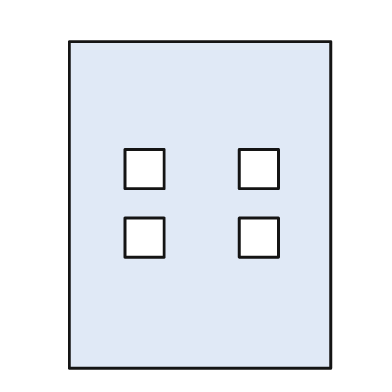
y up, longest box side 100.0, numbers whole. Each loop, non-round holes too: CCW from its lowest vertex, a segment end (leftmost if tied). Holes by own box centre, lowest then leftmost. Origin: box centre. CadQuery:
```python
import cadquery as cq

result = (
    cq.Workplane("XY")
    .moveTo(-40.0, -50.0)
    .lineTo(40.0, -50.0)
    .lineTo(40.0, 50.0)
    .lineTo(-40.0, 50.0)
    .close()
    .moveTo(-23.0, -16.0)
    .lineTo(-11.0, -16.0)
    .lineTo(-11.0, -4.0)
    .lineTo(-23.0, -4.0)
    .close()
    .moveTo(12.0, -16.0)
    .lineTo(24.0, -16.0)
    .lineTo(24.0, -4.0)
    .lineTo(12.0, -4.0)
    .close()
    .moveTo(-23.0, 5.0)
    .lineTo(-11.0, 5.0)
    .lineTo(-11.0, 17.0)
    .lineTo(-23.0, 17.0)
    .close()
    .moveTo(12.0, 5.0)
    .lineTo(24.0, 5.0)
    .lineTo(24.0, 17.0)
    .lineTo(12.0, 17.0)
    .close()
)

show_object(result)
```